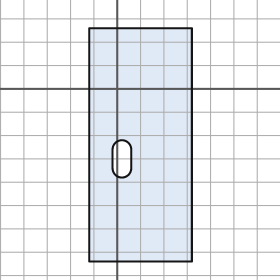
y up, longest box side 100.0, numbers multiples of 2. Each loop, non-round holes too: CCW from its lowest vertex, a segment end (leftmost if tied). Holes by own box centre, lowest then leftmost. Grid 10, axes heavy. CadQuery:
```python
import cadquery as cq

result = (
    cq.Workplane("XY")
    .moveTo(-12.0, -74.0)
    .lineTo(32.0, -74.0)
    .lineTo(32.0, 26.0)
    .lineTo(-12.0, 26.0)
    .close()
    .moveTo(-2.0, -34.0)
    .threePointArc((2.0, -38.0), (6.0, -34.0))
    .lineTo(6.0, -26.0)
    .threePointArc((2.0, -22.0), (-2.0, -26.0))
    .close()
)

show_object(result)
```